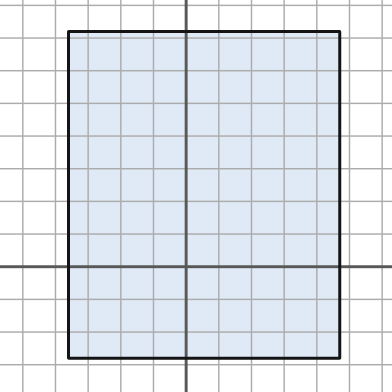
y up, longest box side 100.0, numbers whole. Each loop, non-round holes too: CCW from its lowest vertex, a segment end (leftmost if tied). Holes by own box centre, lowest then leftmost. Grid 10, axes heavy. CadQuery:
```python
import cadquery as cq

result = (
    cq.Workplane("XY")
    .moveTo(-36.0, -28.0)
    .lineTo(47.0, -28.0)
    .lineTo(47.0, 72.0)
    .lineTo(-36.0, 72.0)
    .close()
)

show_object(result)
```